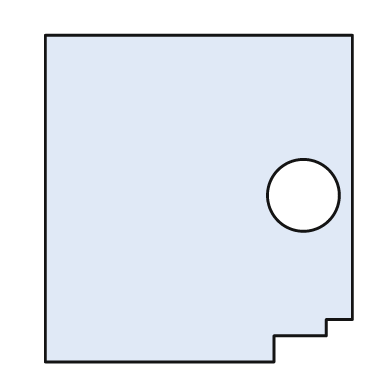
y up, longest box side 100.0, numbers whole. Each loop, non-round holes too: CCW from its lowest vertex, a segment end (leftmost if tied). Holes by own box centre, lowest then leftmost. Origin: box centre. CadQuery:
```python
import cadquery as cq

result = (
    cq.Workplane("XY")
    .moveTo(-47.0, -50.0)
    .lineTo(23.0, -50.0)
    .lineTo(23.0, -42.0)
    .lineTo(39.0, -42.0)
    .lineTo(39.0, -37.0)
    .lineTo(47.0, -37.0)
    .lineTo(47.0, 50.0)
    .lineTo(-47.0, 50.0)
    .close()
    .moveTo(32.0, 1.0)
    .circle(11.0)
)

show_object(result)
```